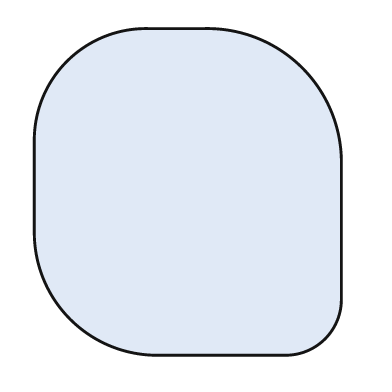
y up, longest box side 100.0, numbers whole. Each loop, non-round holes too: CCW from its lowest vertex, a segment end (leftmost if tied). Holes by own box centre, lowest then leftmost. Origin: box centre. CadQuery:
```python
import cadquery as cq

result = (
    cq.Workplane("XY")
    .moveTo(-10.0, -50.0)
    .lineTo(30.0, -50.0)
    .threePointArc((42.0, -45.0), (47.0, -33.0))
    .lineTo(47.0, 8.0)
    .threePointArc((35.0, 38.0), (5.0, 50.0))
    .lineTo(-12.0, 50.0)
    .threePointArc((-37.0, 40.0), (-47.0, 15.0))
    .lineTo(-47.0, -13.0)
    .threePointArc((-36.0, -39.0), (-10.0, -50.0))
    .close()
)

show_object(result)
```